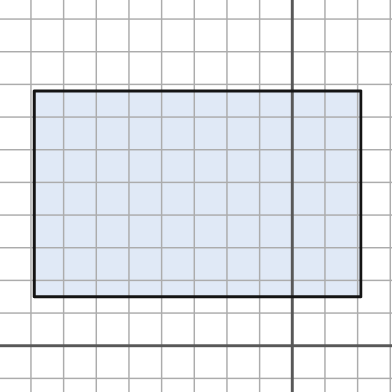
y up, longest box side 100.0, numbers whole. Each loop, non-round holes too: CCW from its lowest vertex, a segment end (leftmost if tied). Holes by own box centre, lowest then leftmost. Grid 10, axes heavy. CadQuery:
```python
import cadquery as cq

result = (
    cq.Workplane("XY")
    .moveTo(-79.0, 15.0)
    .lineTo(21.0, 15.0)
    .lineTo(21.0, 78.0)
    .lineTo(-79.0, 78.0)
    .close()
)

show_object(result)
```